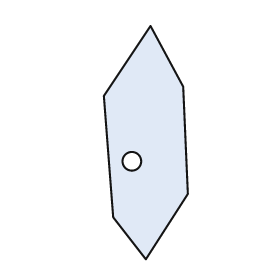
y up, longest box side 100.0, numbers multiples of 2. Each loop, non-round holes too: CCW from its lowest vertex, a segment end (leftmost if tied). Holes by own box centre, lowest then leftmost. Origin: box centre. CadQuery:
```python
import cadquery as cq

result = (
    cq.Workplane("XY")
    .moveTo(0.0, -50.0)
    .lineTo(18.0, -22.0)
    .lineTo(16.0, 24.0)
    .lineTo(2.0, 50.0)
    .lineTo(-18.0, 20.0)
    .lineTo(-14.0, -32.0)
    .close()
    .moveTo(-6.0, -8.0)
    .circle(4.0)
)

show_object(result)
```